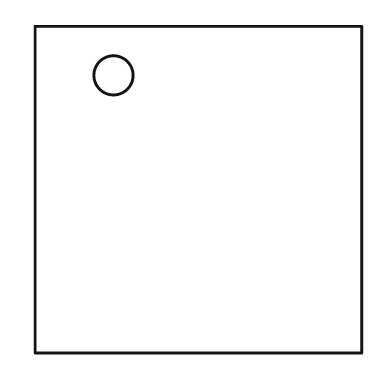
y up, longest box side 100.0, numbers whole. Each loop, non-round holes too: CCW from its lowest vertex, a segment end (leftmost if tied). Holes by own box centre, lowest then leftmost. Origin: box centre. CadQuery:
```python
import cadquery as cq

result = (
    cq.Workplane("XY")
    .moveTo(-50.0, -50.0)
    .lineTo(50.0, -50.0)
    .lineTo(50.0, 50.0)
    .lineTo(-50.0, 50.0)
    .close()
    .moveTo(-26.0, 35.0)
    .circle(6.0)
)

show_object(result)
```